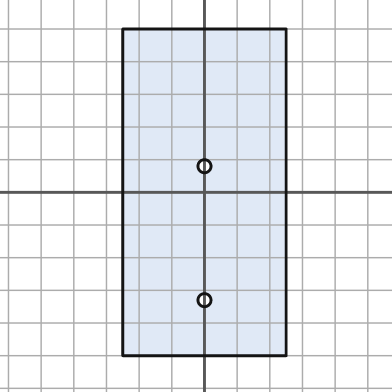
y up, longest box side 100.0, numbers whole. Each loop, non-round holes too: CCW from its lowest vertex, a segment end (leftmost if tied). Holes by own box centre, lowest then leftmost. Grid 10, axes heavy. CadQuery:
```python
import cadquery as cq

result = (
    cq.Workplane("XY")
    .moveTo(-25.0, -50.0)
    .lineTo(25.0, -50.0)
    .lineTo(25.0, 50.0)
    .lineTo(-25.0, 50.0)
    .close()
    .moveTo(0.0, -33.0)
    .circle(2.0)
    .moveTo(0.0, 8.0)
    .circle(2.0)
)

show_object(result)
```